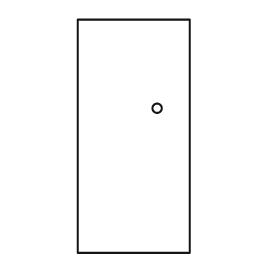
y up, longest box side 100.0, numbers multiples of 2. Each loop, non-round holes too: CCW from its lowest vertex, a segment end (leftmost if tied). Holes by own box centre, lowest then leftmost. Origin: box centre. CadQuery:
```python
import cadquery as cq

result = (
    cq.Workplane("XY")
    .moveTo(-24.0, -50.0)
    .lineTo(24.0, -50.0)
    .lineTo(24.0, 50.0)
    .lineTo(-24.0, 50.0)
    .close()
    .moveTo(10.0, 12.0)
    .circle(2.0)
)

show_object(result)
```